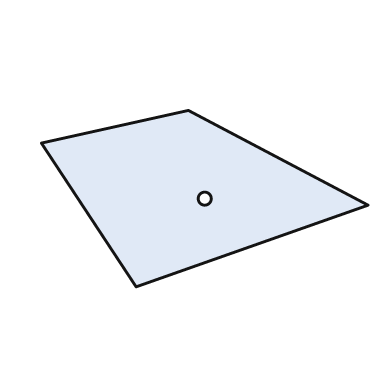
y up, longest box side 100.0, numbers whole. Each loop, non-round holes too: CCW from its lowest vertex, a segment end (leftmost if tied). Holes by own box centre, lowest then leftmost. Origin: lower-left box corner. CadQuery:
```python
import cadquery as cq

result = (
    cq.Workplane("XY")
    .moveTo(29.0, 0.0)
    .lineTo(100.0, 25.0)
    .lineTo(45.0, 54.0)
    .lineTo(0.0, 44.0)
    .close()
    .moveTo(50.0, 27.0)
    .circle(2.0)
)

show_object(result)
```